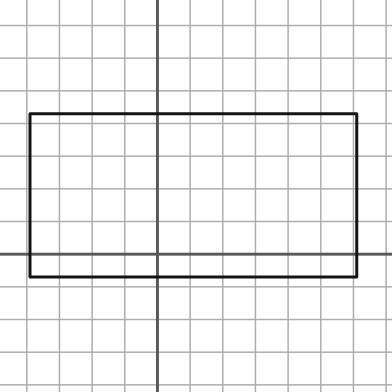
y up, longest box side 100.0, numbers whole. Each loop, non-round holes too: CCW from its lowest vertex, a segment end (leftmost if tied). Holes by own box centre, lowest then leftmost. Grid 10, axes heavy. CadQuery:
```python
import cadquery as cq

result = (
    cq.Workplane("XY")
    .moveTo(-39.0, -7.0)
    .lineTo(61.0, -7.0)
    .lineTo(61.0, 43.0)
    .lineTo(-39.0, 43.0)
    .close()
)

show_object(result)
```